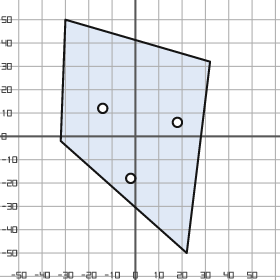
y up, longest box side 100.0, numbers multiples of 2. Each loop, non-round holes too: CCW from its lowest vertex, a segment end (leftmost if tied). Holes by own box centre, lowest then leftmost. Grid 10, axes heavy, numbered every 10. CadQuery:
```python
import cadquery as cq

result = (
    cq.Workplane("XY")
    .moveTo(22.0, -50.0)
    .lineTo(32.0, 32.0)
    .lineTo(-30.0, 50.0)
    .lineTo(-32.0, -2.0)
    .close()
    .moveTo(-2.0, -18.0)
    .circle(2.0)
    .moveTo(18.0, 6.0)
    .circle(2.0)
    .moveTo(-14.0, 12.0)
    .circle(2.0)
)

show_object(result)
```